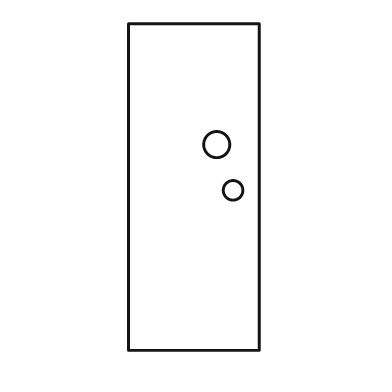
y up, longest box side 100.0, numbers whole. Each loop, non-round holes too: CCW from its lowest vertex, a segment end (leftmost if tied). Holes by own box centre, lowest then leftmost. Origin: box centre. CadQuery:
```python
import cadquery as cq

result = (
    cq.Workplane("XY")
    .moveTo(-20.0, -50.0)
    .lineTo(20.0, -50.0)
    .lineTo(20.0, 50.0)
    .lineTo(-20.0, 50.0)
    .close()
    .moveTo(12.0, -1.0)
    .circle(3.0)
    .moveTo(7.0, 13.0)
    .circle(4.0)
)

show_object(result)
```